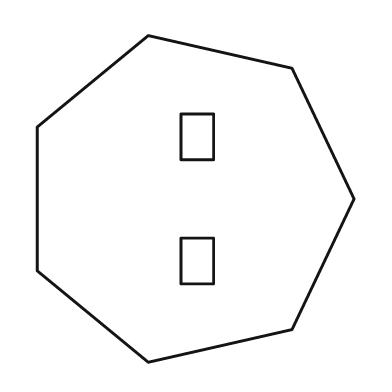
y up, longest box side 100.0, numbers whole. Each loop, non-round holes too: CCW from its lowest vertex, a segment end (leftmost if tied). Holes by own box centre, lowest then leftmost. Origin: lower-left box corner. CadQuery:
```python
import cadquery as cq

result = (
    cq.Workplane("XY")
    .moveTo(34.0, 0.0)
    .lineTo(78.0, 10.0)
    .lineTo(97.0, 50.0)
    .lineTo(78.0, 90.0)
    .lineTo(34.0, 100.0)
    .lineTo(0.0, 72.0)
    .lineTo(0.0, 28.0)
    .close()
    .moveTo(44.0, 24.0)
    .lineTo(54.0, 24.0)
    .lineTo(54.0, 38.0)
    .lineTo(44.0, 38.0)
    .close()
    .moveTo(44.0, 62.0)
    .lineTo(54.0, 62.0)
    .lineTo(54.0, 76.0)
    .lineTo(44.0, 76.0)
    .close()
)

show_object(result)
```